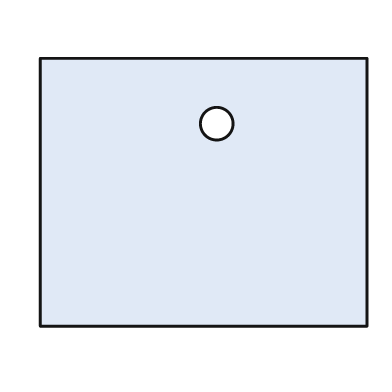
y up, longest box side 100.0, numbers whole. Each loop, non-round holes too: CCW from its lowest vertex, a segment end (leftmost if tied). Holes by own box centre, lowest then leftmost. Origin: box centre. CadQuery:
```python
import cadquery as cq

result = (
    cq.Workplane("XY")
    .moveTo(-50.0, -41.0)
    .lineTo(50.0, -41.0)
    .lineTo(50.0, 41.0)
    .lineTo(-50.0, 41.0)
    .close()
    .moveTo(4.0, 21.0)
    .circle(5.0)
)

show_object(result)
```